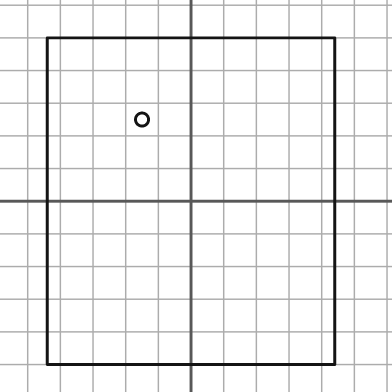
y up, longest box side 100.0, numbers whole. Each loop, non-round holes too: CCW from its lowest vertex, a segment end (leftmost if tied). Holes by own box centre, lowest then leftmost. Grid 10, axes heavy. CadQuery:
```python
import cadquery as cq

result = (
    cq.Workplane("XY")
    .moveTo(-44.0, -50.0)
    .lineTo(44.0, -50.0)
    .lineTo(44.0, 50.0)
    .lineTo(-44.0, 50.0)
    .close()
    .moveTo(-15.0, 25.0)
    .circle(2.0)
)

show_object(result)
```